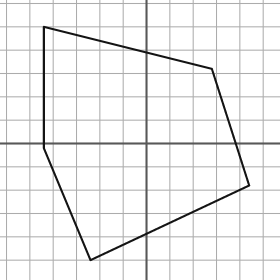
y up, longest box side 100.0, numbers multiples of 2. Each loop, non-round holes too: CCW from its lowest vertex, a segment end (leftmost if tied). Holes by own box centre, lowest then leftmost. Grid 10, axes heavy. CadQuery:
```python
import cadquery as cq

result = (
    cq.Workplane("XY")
    .moveTo(-24.0, -50.0)
    .lineTo(44.0, -18.0)
    .lineTo(28.0, 32.0)
    .lineTo(-44.0, 50.0)
    .lineTo(-44.0, -2.0)
    .close()
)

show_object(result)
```